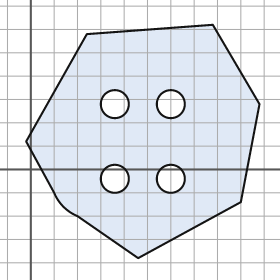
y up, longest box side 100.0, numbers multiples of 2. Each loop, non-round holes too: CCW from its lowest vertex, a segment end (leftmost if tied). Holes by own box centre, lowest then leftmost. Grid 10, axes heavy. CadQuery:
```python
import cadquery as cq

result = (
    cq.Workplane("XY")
    .moveTo(46.0, -38.0)
    .lineTo(90.0, -14.0)
    .lineTo(98.0, 28.0)
    .lineTo(78.0, 62.0)
    .lineTo(24.0, 58.0)
    .lineTo(-2.0, 12.0)
    .lineTo(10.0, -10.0)
    .threePointArc((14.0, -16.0), (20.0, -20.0))
    .close()
    .moveTo(36.0, -4.0)
    .circle(6.0)
    .moveTo(60.0, -4.0)
    .circle(6.0)
    .moveTo(36.0, 28.0)
    .circle(6.0)
    .moveTo(60.0, 28.0)
    .circle(6.0)
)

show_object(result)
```